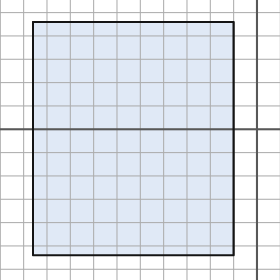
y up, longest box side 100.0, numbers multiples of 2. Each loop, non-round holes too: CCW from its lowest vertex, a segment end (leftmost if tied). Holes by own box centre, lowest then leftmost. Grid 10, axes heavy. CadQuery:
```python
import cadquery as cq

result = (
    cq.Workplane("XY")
    .moveTo(-96.0, -54.0)
    .lineTo(-10.0, -54.0)
    .lineTo(-10.0, 46.0)
    .lineTo(-96.0, 46.0)
    .close()
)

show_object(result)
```